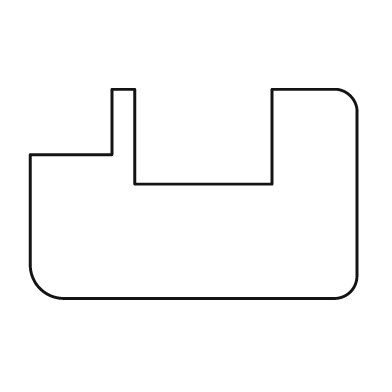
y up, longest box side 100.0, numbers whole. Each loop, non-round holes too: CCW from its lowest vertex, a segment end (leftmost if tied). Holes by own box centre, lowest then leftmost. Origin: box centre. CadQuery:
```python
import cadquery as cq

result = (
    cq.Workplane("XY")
    .moveTo(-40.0, -32.0)
    .lineTo(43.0, -32.0)
    .threePointArc((48.0, -30.0), (50.0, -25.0))
    .lineTo(50.0, 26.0)
    .threePointArc((48.0, 30.0), (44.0, 32.0))
    .lineTo(24.0, 32.0)
    .lineTo(24.0, 3.0)
    .lineTo(-18.0, 3.0)
    .lineTo(-18.0, 32.0)
    .lineTo(-25.0, 32.0)
    .lineTo(-25.0, 12.0)
    .lineTo(-50.0, 12.0)
    .lineTo(-50.0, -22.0)
    .threePointArc((-47.0, -29.0), (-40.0, -32.0))
    .close()
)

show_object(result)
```